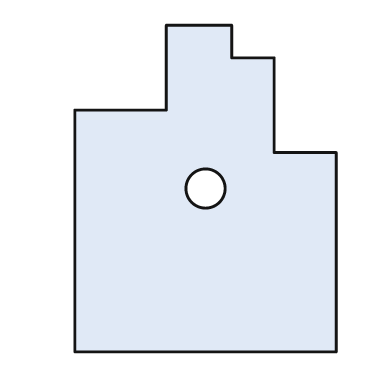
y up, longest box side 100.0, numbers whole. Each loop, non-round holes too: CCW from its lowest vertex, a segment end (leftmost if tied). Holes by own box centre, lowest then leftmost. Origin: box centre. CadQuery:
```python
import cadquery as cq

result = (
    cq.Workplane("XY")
    .moveTo(-40.0, -50.0)
    .lineTo(40.0, -50.0)
    .lineTo(40.0, 11.0)
    .lineTo(21.0, 11.0)
    .lineTo(21.0, 40.0)
    .lineTo(8.0, 40.0)
    .lineTo(8.0, 50.0)
    .lineTo(-12.0, 50.0)
    .lineTo(-12.0, 24.0)
    .lineTo(-40.0, 24.0)
    .close()
    .moveTo(0.0, 0.0)
    .circle(6.0)
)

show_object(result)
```